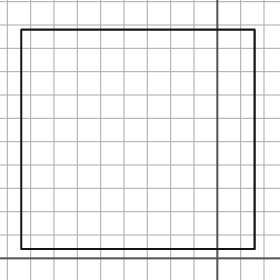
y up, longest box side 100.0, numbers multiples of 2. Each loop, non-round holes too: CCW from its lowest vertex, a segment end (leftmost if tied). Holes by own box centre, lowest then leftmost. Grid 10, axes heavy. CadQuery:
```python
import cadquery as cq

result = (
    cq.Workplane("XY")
    .moveTo(-84.0, 4.0)
    .lineTo(16.0, 4.0)
    .lineTo(16.0, 98.0)
    .lineTo(-84.0, 98.0)
    .close()
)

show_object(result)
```